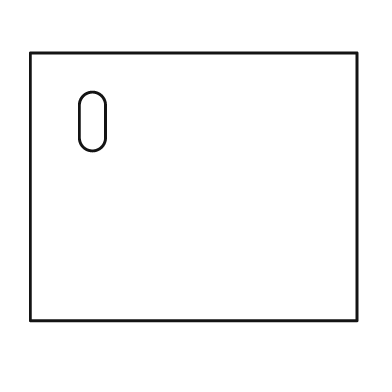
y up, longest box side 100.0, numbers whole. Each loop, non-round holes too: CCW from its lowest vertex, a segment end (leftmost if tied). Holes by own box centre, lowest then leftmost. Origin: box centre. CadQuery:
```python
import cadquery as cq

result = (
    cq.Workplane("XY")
    .moveTo(-50.0, -41.0)
    .lineTo(50.0, -41.0)
    .lineTo(50.0, 41.0)
    .lineTo(-50.0, 41.0)
    .close()
    .moveTo(-35.0, 15.0)
    .threePointArc((-31.0, 11.0), (-27.0, 15.0))
    .lineTo(-27.0, 25.0)
    .threePointArc((-31.0, 29.0), (-35.0, 25.0))
    .close()
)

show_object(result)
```